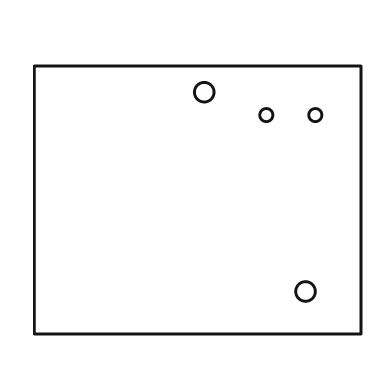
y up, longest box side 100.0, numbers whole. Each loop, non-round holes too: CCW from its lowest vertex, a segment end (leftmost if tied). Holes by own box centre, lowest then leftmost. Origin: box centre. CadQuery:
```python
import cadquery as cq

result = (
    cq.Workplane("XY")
    .moveTo(-50.0, -41.0)
    .lineTo(50.0, -41.0)
    .lineTo(50.0, 41.0)
    .lineTo(-50.0, 41.0)
    .close()
    .moveTo(33.0, -28.0)
    .circle(3.0)
    .moveTo(21.0, 26.0)
    .circle(2.0)
    .moveTo(36.0, 26.0)
    .circle(2.0)
    .moveTo(2.0, 33.0)
    .circle(3.0)
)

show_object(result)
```